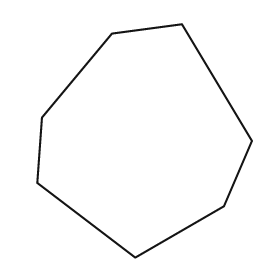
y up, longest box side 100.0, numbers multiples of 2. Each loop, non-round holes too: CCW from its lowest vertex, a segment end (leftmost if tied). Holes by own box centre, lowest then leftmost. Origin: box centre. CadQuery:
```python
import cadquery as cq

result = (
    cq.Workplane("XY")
    .moveTo(-4.0, -50.0)
    .lineTo(34.0, -28.0)
    .lineTo(46.0, 0.0)
    .lineTo(16.0, 50.0)
    .lineTo(-14.0, 46.0)
    .lineTo(-44.0, 10.0)
    .lineTo(-46.0, -18.0)
    .close()
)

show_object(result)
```